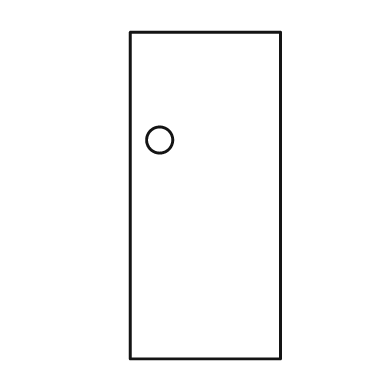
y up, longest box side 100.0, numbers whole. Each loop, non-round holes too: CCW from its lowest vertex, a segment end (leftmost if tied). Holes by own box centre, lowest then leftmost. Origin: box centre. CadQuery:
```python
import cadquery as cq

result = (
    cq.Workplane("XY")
    .moveTo(-23.0, -50.0)
    .lineTo(23.0, -50.0)
    .lineTo(23.0, 50.0)
    .lineTo(-23.0, 50.0)
    .close()
    .moveTo(-14.0, 17.0)
    .circle(4.0)
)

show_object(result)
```